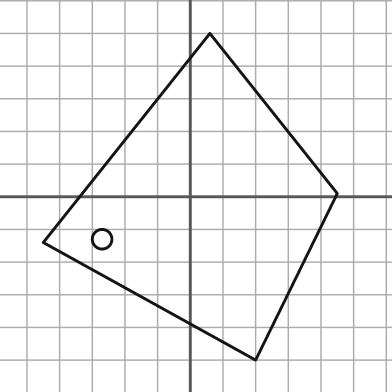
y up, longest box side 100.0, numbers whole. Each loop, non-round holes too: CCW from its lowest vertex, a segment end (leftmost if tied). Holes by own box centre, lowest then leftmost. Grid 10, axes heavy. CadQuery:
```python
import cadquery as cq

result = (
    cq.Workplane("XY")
    .moveTo(20.0, -50.0)
    .lineTo(45.0, 1.0)
    .lineTo(6.0, 50.0)
    .lineTo(-45.0, -14.0)
    .close()
    .moveTo(-27.0, -13.0)
    .circle(3.0)
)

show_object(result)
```